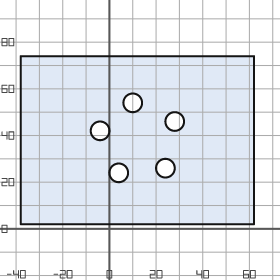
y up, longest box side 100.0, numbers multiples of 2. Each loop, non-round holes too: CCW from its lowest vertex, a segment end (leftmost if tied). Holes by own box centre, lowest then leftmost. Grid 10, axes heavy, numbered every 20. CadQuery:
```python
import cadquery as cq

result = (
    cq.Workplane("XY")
    .moveTo(-38.0, 2.0)
    .lineTo(62.0, 2.0)
    .lineTo(62.0, 74.0)
    .lineTo(-38.0, 74.0)
    .close()
    .moveTo(4.0, 24.0)
    .circle(4.0)
    .moveTo(24.0, 26.0)
    .circle(4.0)
    .moveTo(-4.0, 42.0)
    .circle(4.0)
    .moveTo(28.0, 46.0)
    .circle(4.0)
    .moveTo(10.0, 54.0)
    .circle(4.0)
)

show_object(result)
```